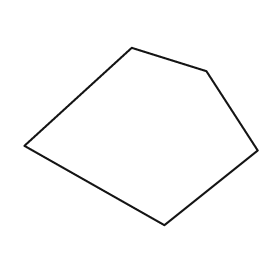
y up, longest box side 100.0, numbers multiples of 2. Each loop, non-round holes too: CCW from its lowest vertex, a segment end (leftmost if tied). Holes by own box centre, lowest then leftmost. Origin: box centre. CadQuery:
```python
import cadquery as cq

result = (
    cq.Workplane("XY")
    .moveTo(10.0, -38.0)
    .lineTo(50.0, -6.0)
    .lineTo(28.0, 28.0)
    .lineTo(-4.0, 38.0)
    .lineTo(-50.0, -4.0)
    .close()
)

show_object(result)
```